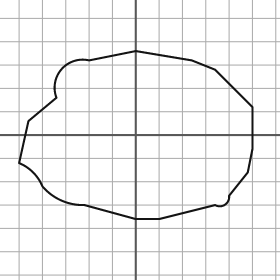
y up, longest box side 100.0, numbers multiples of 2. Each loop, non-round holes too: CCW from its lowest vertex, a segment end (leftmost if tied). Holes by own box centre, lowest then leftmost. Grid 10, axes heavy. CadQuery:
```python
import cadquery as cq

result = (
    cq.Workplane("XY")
    .moveTo(0.0, -36.0)
    .lineTo(10.0, -36.0)
    .lineTo(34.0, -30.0)
    .threePointArc((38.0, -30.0), (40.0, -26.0))
    .lineTo(48.0, -16.0)
    .lineTo(50.0, -6.0)
    .lineTo(50.0, 12.0)
    .lineTo(34.0, 28.0)
    .lineTo(24.0, 32.0)
    .lineTo(0.0, 36.0)
    .lineTo(-20.0, 32.0)
    .threePointArc((-32.0, 28.0), (-34.0, 16.0))
    .lineTo(-46.0, 6.0)
    .lineTo(-50.0, -12.0)
    .threePointArc((-44.0, -16.0), (-40.0, -22.0))
    .threePointArc((-32.0, -28.0), (-22.0, -30.0))
    .close()
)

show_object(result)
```